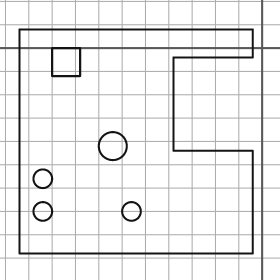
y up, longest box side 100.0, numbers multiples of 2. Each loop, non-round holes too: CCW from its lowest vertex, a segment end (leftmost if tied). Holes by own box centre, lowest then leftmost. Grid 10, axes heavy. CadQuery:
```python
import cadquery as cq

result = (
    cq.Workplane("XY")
    .moveTo(-104.0, -88.0)
    .lineTo(-4.0, -88.0)
    .lineTo(-4.0, -44.0)
    .lineTo(-38.0, -44.0)
    .lineTo(-38.0, -4.0)
    .lineTo(-4.0, -4.0)
    .lineTo(-4.0, 8.0)
    .lineTo(-104.0, 8.0)
    .close()
    .moveTo(-94.0, -70.0)
    .circle(4.0)
    .moveTo(-56.0, -70.0)
    .circle(4.0)
    .moveTo(-94.0, -56.0)
    .circle(4.0)
    .moveTo(-64.0, -42.0)
    .circle(6.0)
    .moveTo(-90.0, -12.0)
    .lineTo(-78.0, -12.0)
    .lineTo(-78.0, 0.0)
    .lineTo(-90.0, 0.0)
    .close()
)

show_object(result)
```